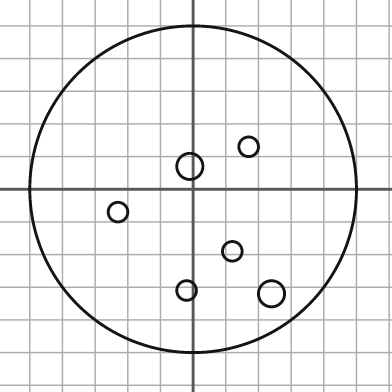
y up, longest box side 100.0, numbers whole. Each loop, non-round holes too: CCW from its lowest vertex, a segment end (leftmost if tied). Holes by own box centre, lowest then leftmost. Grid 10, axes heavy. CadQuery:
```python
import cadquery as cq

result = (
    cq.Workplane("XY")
    .moveTo(0.0, 0.0)
    .circle(50.0)
    .moveTo(24.0, -32.0)
    .circle(4.0)
    .moveTo(-2.0, -31.0)
    .circle(3.0)
    .moveTo(12.0, -19.0)
    .circle(3.0)
    .moveTo(-23.0, -7.0)
    .circle(3.0)
    .moveTo(-1.0, 7.0)
    .circle(4.0)
    .moveTo(17.0, 13.0)
    .circle(3.0)
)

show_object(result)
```